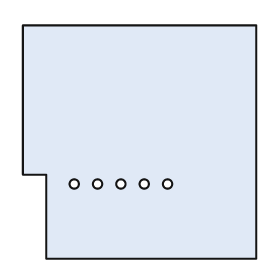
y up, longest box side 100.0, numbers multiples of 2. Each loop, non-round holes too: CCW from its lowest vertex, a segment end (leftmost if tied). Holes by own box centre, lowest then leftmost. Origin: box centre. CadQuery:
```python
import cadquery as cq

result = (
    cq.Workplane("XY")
    .moveTo(-40.0, -50.0)
    .lineTo(50.0, -50.0)
    .lineTo(50.0, 50.0)
    .lineTo(-50.0, 50.0)
    .lineTo(-50.0, -14.0)
    .lineTo(-40.0, -14.0)
    .close()
    .moveTo(-28.0, -18.0)
    .circle(2.0)
    .moveTo(-18.0, -18.0)
    .circle(2.0)
    .moveTo(-8.0, -18.0)
    .circle(2.0)
    .moveTo(2.0, -18.0)
    .circle(2.0)
    .moveTo(12.0, -18.0)
    .circle(2.0)
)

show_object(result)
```